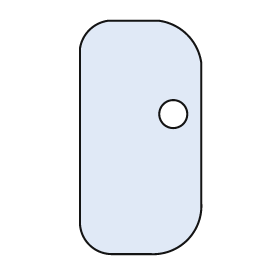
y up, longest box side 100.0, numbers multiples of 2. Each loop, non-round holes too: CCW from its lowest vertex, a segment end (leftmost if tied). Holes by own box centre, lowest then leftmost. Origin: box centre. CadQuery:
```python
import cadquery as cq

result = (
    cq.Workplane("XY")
    .moveTo(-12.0, -50.0)
    .lineTo(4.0, -50.0)
    .threePointArc((20.0, -44.0), (26.0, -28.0))
    .lineTo(26.0, 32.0)
    .threePointArc((20.0, 44.0), (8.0, 50.0))
    .lineTo(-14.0, 50.0)
    .threePointArc((-22.0, 46.0), (-26.0, 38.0))
    .lineTo(-26.0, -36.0)
    .threePointArc((-22.0, -46.0), (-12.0, -50.0))
    .close()
    .moveTo(14.0, 10.0)
    .circle(6.0)
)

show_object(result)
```